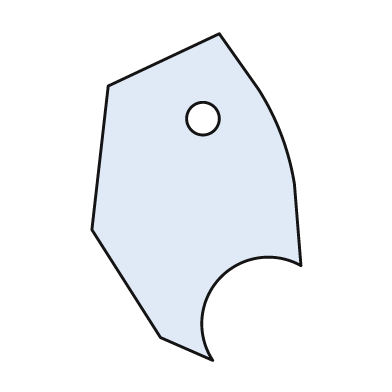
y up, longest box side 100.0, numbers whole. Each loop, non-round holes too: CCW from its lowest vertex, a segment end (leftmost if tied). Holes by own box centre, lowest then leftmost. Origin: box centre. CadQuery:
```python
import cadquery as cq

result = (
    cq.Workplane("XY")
    .moveTo(5.0, -50.0)
    .threePointArc((7.0, -25.0), (32.0, -21.0))
    .lineTo(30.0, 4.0)
    .threePointArc((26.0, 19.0), (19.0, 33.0))
    .lineTo(7.0, 50.0)
    .lineTo(-27.0, 34.0)
    .lineTo(-32.0, -10.0)
    .lineTo(-11.0, -43.0)
    .close()
    .moveTo(2.0, 24.0)
    .circle(5.0)
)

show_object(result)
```